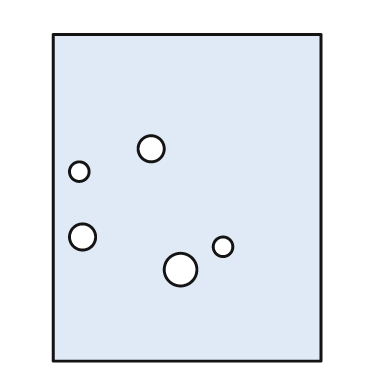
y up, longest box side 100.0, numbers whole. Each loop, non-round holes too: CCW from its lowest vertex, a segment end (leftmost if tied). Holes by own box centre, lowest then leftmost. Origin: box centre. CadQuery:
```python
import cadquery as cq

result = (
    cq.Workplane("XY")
    .moveTo(-41.0, -50.0)
    .lineTo(41.0, -50.0)
    .lineTo(41.0, 50.0)
    .lineTo(-41.0, 50.0)
    .close()
    .moveTo(-2.0, -22.0)
    .circle(5.0)
    .moveTo(11.0, -15.0)
    .circle(3.0)
    .moveTo(-32.0, -12.0)
    .circle(4.0)
    .moveTo(-33.0, 8.0)
    .circle(3.0)
    .moveTo(-11.0, 15.0)
    .circle(4.0)
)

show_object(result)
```